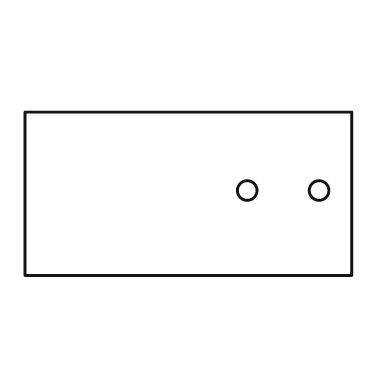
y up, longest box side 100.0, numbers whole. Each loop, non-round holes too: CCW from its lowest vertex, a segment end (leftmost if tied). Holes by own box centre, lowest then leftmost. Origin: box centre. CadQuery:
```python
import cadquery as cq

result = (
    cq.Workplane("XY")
    .moveTo(-50.0, -25.0)
    .lineTo(50.0, -25.0)
    .lineTo(50.0, 25.0)
    .lineTo(-50.0, 25.0)
    .close()
    .moveTo(18.0, 1.0)
    .circle(3.0)
    .moveTo(40.0, 1.0)
    .circle(3.0)
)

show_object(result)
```